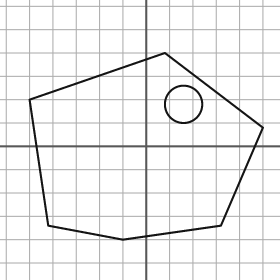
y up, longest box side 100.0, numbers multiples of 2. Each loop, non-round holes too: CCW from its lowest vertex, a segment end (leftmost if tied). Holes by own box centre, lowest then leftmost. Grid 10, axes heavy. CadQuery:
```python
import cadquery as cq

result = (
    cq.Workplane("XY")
    .moveTo(-10.0, -40.0)
    .lineTo(32.0, -34.0)
    .lineTo(50.0, 8.0)
    .lineTo(8.0, 40.0)
    .lineTo(-50.0, 20.0)
    .lineTo(-42.0, -34.0)
    .close()
    .moveTo(16.0, 18.0)
    .circle(8.0)
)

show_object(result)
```